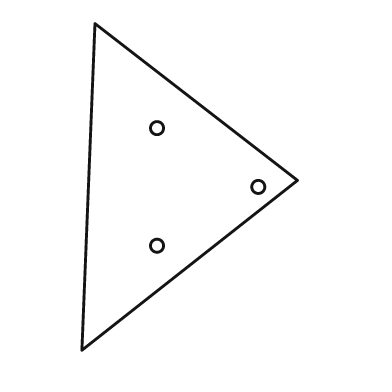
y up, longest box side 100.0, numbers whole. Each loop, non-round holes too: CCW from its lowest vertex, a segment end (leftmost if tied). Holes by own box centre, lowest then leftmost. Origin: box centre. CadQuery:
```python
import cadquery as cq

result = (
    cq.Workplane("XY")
    .moveTo(-33.0, -50.0)
    .lineTo(33.0, 2.0)
    .lineTo(-29.0, 50.0)
    .close()
    .moveTo(-10.0, -18.0)
    .circle(2.0)
    .moveTo(21.0, 0.0)
    .circle(2.0)
    .moveTo(-10.0, 18.0)
    .circle(2.0)
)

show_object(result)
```